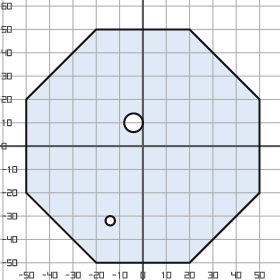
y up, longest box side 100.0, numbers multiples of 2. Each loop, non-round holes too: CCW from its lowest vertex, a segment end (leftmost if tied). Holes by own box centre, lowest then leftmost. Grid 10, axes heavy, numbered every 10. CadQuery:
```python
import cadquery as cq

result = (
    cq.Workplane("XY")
    .moveTo(-20.0, -50.0)
    .lineTo(20.0, -50.0)
    .lineTo(50.0, -20.0)
    .lineTo(50.0, 20.0)
    .lineTo(20.0, 50.0)
    .lineTo(-20.0, 50.0)
    .lineTo(-50.0, 20.0)
    .lineTo(-50.0, -20.0)
    .close()
    .moveTo(-14.0, -32.0)
    .circle(2.0)
    .moveTo(-4.0, 10.0)
    .circle(4.0)
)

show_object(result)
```